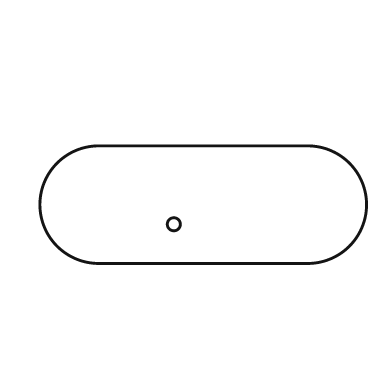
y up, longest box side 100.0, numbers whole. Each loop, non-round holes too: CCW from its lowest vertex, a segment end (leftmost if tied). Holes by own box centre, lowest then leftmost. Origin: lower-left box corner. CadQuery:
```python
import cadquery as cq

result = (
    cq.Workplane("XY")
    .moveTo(18.0, 0.0)
    .lineTo(82.0, 0.0)
    .threePointArc((100.0, 18.0), (82.0, 36.0))
    .lineTo(18.0, 36.0)
    .threePointArc((0.0, 18.0), (18.0, 0.0))
    .close()
    .moveTo(41.0, 12.0)
    .circle(2.0)
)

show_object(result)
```